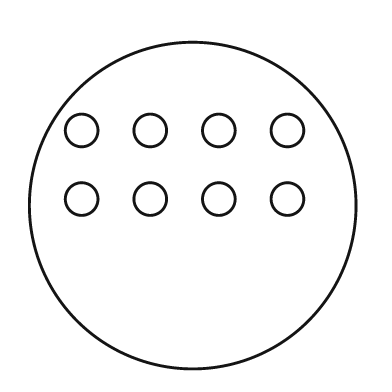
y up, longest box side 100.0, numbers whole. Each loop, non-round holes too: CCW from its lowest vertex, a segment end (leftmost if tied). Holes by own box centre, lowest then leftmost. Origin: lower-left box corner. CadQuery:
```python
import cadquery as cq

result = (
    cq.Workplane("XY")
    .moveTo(50.0, 50.0)
    .circle(50.0)
    .moveTo(16.0, 52.0)
    .circle(5.0)
    .moveTo(37.0, 52.0)
    .circle(5.0)
    .moveTo(58.0, 52.0)
    .circle(5.0)
    .moveTo(79.0, 52.0)
    .circle(5.0)
    .moveTo(16.0, 73.0)
    .circle(5.0)
    .moveTo(37.0, 73.0)
    .circle(5.0)
    .moveTo(58.0, 73.0)
    .circle(5.0)
    .moveTo(79.0, 73.0)
    .circle(5.0)
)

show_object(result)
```